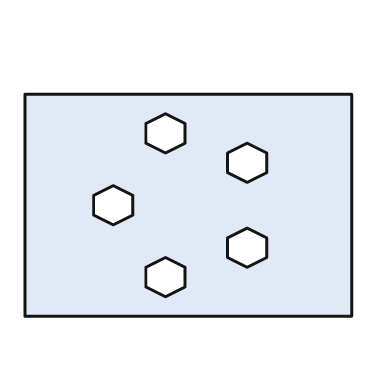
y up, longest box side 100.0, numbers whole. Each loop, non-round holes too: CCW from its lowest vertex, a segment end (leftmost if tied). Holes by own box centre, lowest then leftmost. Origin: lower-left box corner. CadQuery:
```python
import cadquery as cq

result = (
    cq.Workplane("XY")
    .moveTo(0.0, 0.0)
    .lineTo(100.0, 0.0)
    .lineTo(100.0, 68.0)
    .lineTo(0.0, 68.0)
    .close()
    .moveTo(43.0, 6.0)
    .lineTo(49.0, 9.0)
    .lineTo(49.0, 15.0)
    .lineTo(43.0, 18.0)
    .lineTo(37.0, 15.0)
    .lineTo(37.0, 9.0)
    .close()
    .moveTo(68.0, 15.0)
    .lineTo(74.0, 18.0)
    .lineTo(74.0, 24.0)
    .lineTo(68.0, 27.0)
    .lineTo(62.0, 24.0)
    .lineTo(62.0, 18.0)
    .close()
    .moveTo(27.0, 28.0)
    .lineTo(33.0, 31.0)
    .lineTo(33.0, 37.0)
    .lineTo(27.0, 40.0)
    .lineTo(21.0, 37.0)
    .lineTo(21.0, 31.0)
    .close()
    .moveTo(68.0, 41.0)
    .lineTo(74.0, 44.0)
    .lineTo(74.0, 50.0)
    .lineTo(68.0, 53.0)
    .lineTo(62.0, 50.0)
    .lineTo(62.0, 44.0)
    .close()
    .moveTo(43.0, 50.0)
    .lineTo(49.0, 53.0)
    .lineTo(49.0, 59.0)
    .lineTo(43.0, 62.0)
    .lineTo(37.0, 59.0)
    .lineTo(37.0, 53.0)
    .close()
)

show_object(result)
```